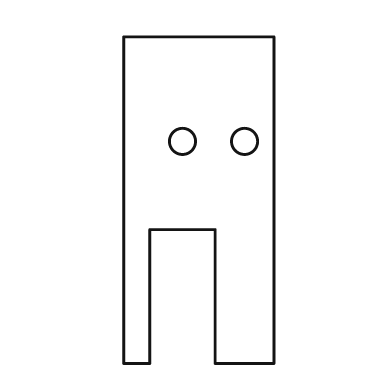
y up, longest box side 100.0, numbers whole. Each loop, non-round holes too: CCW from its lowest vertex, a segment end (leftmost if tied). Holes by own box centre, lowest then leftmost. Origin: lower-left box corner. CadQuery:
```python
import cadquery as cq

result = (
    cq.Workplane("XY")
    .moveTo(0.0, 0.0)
    .lineTo(8.0, 0.0)
    .lineTo(8.0, 41.0)
    .lineTo(28.0, 41.0)
    .lineTo(28.0, 0.0)
    .lineTo(46.0, 0.0)
    .lineTo(46.0, 100.0)
    .lineTo(0.0, 100.0)
    .close()
    .moveTo(18.0, 68.0)
    .circle(4.0)
    .moveTo(37.0, 68.0)
    .circle(4.0)
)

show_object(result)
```